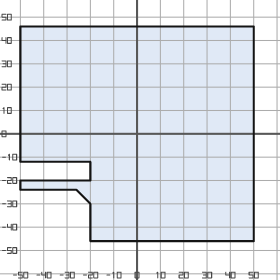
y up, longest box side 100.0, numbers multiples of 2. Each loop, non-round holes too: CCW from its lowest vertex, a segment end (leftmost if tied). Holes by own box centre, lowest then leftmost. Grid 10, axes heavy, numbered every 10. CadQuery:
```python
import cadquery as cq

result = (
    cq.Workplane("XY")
    .moveTo(-20.0, -46.0)
    .lineTo(50.0, -46.0)
    .lineTo(50.0, 46.0)
    .lineTo(-50.0, 46.0)
    .lineTo(-50.0, -12.0)
    .lineTo(-20.0, -12.0)
    .lineTo(-20.0, -20.0)
    .lineTo(-50.0, -20.0)
    .lineTo(-50.0, -24.0)
    .lineTo(-26.0, -24.0)
    .lineTo(-20.0, -30.0)
    .close()
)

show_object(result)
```